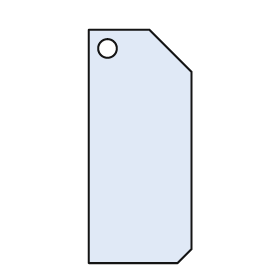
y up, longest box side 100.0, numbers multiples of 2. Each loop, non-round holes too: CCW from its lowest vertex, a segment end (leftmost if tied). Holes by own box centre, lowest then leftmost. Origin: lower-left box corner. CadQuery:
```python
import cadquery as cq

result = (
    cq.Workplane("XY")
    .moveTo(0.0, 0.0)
    .lineTo(38.0, 0.0)
    .lineTo(44.0, 6.0)
    .lineTo(44.0, 82.0)
    .lineTo(26.0, 100.0)
    .lineTo(0.0, 100.0)
    .close()
    .moveTo(8.0, 92.0)
    .circle(4.0)
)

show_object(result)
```